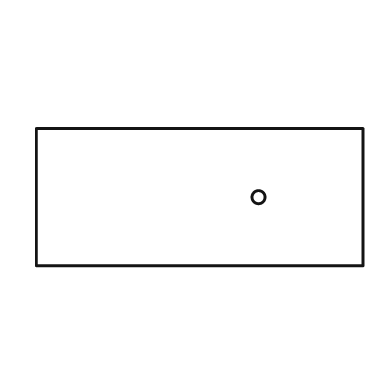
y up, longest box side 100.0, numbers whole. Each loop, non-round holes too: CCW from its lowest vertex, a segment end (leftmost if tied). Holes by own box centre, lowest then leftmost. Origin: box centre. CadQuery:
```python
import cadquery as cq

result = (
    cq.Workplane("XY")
    .moveTo(-50.0, -21.0)
    .lineTo(50.0, -21.0)
    .lineTo(50.0, 21.0)
    .lineTo(-50.0, 21.0)
    .close()
    .moveTo(18.0, 0.0)
    .circle(2.0)
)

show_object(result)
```